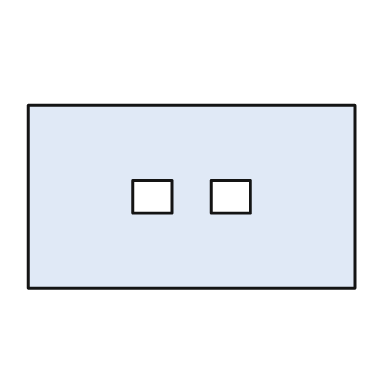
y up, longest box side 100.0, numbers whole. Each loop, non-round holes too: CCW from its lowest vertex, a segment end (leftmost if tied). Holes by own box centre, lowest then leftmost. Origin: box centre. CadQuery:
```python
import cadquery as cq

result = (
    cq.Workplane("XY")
    .moveTo(-50.0, -28.0)
    .lineTo(50.0, -28.0)
    .lineTo(50.0, 28.0)
    .lineTo(-50.0, 28.0)
    .close()
    .moveTo(-18.0, -5.0)
    .lineTo(-6.0, -5.0)
    .lineTo(-6.0, 5.0)
    .lineTo(-18.0, 5.0)
    .close()
    .moveTo(6.0, -5.0)
    .lineTo(18.0, -5.0)
    .lineTo(18.0, 5.0)
    .lineTo(6.0, 5.0)
    .close()
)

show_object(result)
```